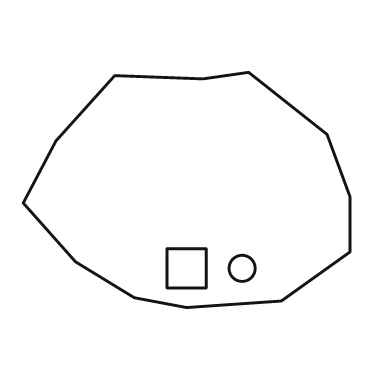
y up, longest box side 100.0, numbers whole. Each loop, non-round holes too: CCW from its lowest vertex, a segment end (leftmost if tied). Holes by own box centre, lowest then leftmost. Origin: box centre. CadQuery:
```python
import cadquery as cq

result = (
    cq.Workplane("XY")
    .moveTo(0.0, -36.0)
    .lineTo(29.0, -34.0)
    .lineTo(50.0, -19.0)
    .lineTo(50.0, -2.0)
    .lineTo(43.0, 17.0)
    .lineTo(19.0, 36.0)
    .lineTo(5.0, 34.0)
    .lineTo(-22.0, 35.0)
    .lineTo(-40.0, 15.0)
    .lineTo(-50.0, -4.0)
    .lineTo(-34.0, -22.0)
    .lineTo(-16.0, -33.0)
    .close()
    .moveTo(-6.0, -30.0)
    .lineTo(6.0, -30.0)
    .lineTo(6.0, -18.0)
    .lineTo(-6.0, -18.0)
    .close()
    .moveTo(17.0, -24.0)
    .circle(4.0)
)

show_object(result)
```